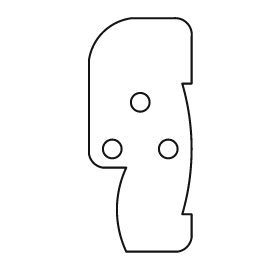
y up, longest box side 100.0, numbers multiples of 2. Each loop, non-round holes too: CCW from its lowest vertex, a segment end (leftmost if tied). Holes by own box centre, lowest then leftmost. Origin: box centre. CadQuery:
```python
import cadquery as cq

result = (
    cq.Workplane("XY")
    .moveTo(-6.0, -50.0)
    .lineTo(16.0, -50.0)
    .threePointArc((20.0, -48.0), (22.0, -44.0))
    .lineTo(22.0, -34.0)
    .lineTo(18.0, -34.0)
    .threePointArc((22.0, -6.0), (18.0, 22.0))
    .lineTo(22.0, 22.0)
    .lineTo(22.0, 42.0)
    .threePointArc((20.0, 48.0), (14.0, 50.0))
    .lineTo(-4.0, 50.0)
    .threePointArc((-16.0, 44.0), (-22.0, 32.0))
    .lineTo(-22.0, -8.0)
    .threePointArc((-20.0, -12.0), (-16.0, -14.0))
    .lineTo(-6.0, -14.0)
    .threePointArc((-10.0, -32.0), (-6.0, -50.0))
    .close()
    .moveTo(-12.0, -6.0)
    .circle(4.0)
    .moveTo(12.0, -6.0)
    .circle(4.0)
    .moveTo(0.0, 14.0)
    .circle(4.0)
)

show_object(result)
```